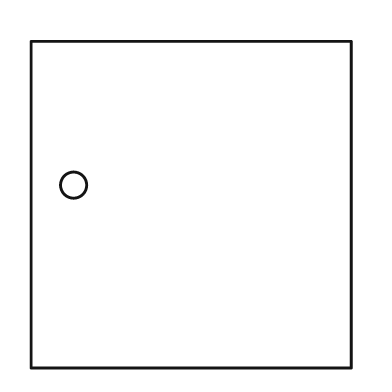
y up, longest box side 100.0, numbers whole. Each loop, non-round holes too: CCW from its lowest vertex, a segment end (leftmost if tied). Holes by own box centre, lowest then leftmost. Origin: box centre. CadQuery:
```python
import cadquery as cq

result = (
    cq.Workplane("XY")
    .moveTo(-49.0, -50.0)
    .lineTo(49.0, -50.0)
    .lineTo(49.0, 50.0)
    .lineTo(-49.0, 50.0)
    .close()
    .moveTo(-36.0, 6.0)
    .circle(4.0)
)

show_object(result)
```